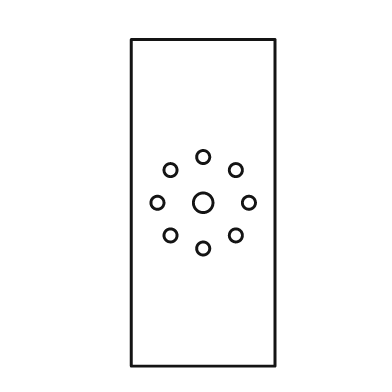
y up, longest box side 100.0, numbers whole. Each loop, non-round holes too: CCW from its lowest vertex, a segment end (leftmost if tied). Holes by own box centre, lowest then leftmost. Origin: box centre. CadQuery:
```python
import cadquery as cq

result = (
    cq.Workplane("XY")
    .moveTo(-22.0, -50.0)
    .lineTo(22.0, -50.0)
    .lineTo(22.0, 50.0)
    .lineTo(-22.0, 50.0)
    .close()
    .moveTo(0.0, -14.0)
    .circle(2.0)
    .moveTo(-10.0, -10.0)
    .circle(2.0)
    .moveTo(10.0, -10.0)
    .circle(2.0)
    .moveTo(-14.0, 0.0)
    .circle(2.0)
    .moveTo(0.0, 0.0)
    .circle(3.0)
    .moveTo(14.0, 0.0)
    .circle(2.0)
    .moveTo(-10.0, 10.0)
    .circle(2.0)
    .moveTo(10.0, 10.0)
    .circle(2.0)
    .moveTo(0.0, 14.0)
    .circle(2.0)
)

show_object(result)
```